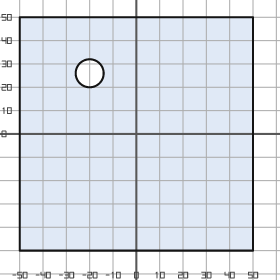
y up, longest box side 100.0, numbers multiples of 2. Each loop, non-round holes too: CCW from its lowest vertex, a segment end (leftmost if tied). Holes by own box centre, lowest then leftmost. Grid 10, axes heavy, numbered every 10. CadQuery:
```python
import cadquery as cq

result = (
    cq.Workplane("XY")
    .moveTo(-50.0, -50.0)
    .lineTo(50.0, -50.0)
    .lineTo(50.0, 50.0)
    .lineTo(-50.0, 50.0)
    .close()
    .moveTo(-20.0, 26.0)
    .circle(6.0)
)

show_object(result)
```